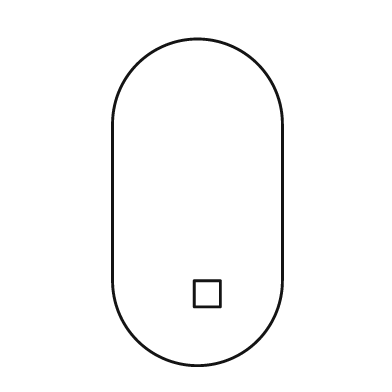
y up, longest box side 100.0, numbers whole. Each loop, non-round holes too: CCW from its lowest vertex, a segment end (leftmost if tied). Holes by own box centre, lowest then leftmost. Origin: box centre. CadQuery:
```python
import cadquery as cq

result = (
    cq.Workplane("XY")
    .moveTo(-26.0, -24.0)
    .threePointArc((0.0, -50.0), (26.0, -24.0))
    .lineTo(26.0, 24.0)
    .threePointArc((0.0, 50.0), (-26.0, 24.0))
    .close()
    .moveTo(-1.0, -32.0)
    .lineTo(7.0, -32.0)
    .lineTo(7.0, -24.0)
    .lineTo(-1.0, -24.0)
    .close()
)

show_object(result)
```